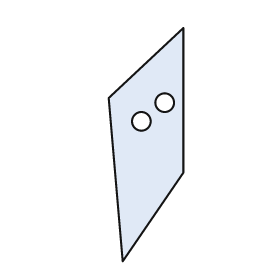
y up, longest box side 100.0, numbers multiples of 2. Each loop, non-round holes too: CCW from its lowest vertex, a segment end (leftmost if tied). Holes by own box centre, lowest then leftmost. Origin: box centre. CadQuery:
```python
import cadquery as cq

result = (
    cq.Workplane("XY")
    .moveTo(-10.0, -50.0)
    .lineTo(16.0, -12.0)
    .lineTo(16.0, 50.0)
    .lineTo(-16.0, 20.0)
    .close()
    .moveTo(-2.0, 10.0)
    .circle(4.0)
    .moveTo(8.0, 18.0)
    .circle(4.0)
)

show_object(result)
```